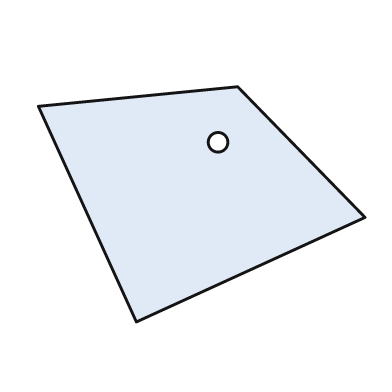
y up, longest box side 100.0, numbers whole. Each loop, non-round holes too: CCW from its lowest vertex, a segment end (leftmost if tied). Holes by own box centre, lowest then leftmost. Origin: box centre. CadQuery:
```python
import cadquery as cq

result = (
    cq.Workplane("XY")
    .moveTo(-20.0, -36.0)
    .lineTo(50.0, -4.0)
    .lineTo(11.0, 36.0)
    .lineTo(-50.0, 30.0)
    .close()
    .moveTo(5.0, 19.0)
    .circle(3.0)
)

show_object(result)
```